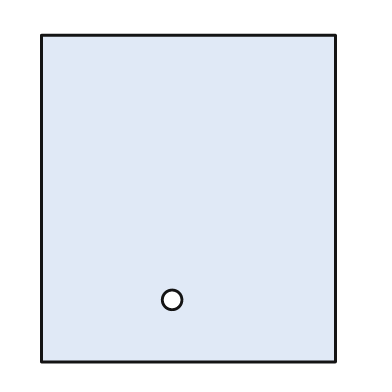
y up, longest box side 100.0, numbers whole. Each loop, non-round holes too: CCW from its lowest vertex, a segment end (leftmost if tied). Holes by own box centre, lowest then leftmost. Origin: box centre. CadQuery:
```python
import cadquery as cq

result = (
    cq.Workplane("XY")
    .moveTo(-45.0, -50.0)
    .lineTo(45.0, -50.0)
    .lineTo(45.0, 50.0)
    .lineTo(-45.0, 50.0)
    .close()
    .moveTo(-5.0, -31.0)
    .circle(3.0)
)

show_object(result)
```